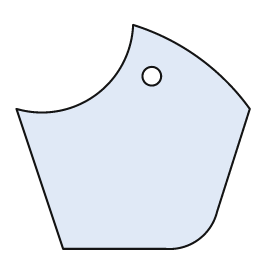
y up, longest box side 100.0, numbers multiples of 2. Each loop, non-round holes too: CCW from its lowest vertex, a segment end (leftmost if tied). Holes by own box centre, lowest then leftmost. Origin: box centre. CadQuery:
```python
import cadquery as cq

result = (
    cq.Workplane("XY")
    .moveTo(-30.0, -48.0)
    .lineTo(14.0, -48.0)
    .threePointArc((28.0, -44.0), (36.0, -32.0))
    .lineTo(50.0, 12.0)
    .threePointArc((28.0, 34.0), (0.0, 48.0))
    .threePointArc((-16.0, 18.0), (-50.0, 12.0))
    .close()
    .moveTo(8.0, 26.0)
    .circle(4.0)
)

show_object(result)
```